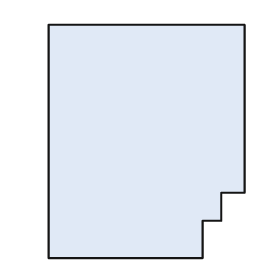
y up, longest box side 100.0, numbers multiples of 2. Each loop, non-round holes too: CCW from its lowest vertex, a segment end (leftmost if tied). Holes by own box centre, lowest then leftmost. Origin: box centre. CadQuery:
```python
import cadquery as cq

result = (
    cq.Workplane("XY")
    .moveTo(-42.0, -50.0)
    .lineTo(24.0, -50.0)
    .lineTo(24.0, -34.0)
    .lineTo(32.0, -34.0)
    .lineTo(32.0, -22.0)
    .lineTo(42.0, -22.0)
    .lineTo(42.0, 50.0)
    .lineTo(-42.0, 50.0)
    .close()
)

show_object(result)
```